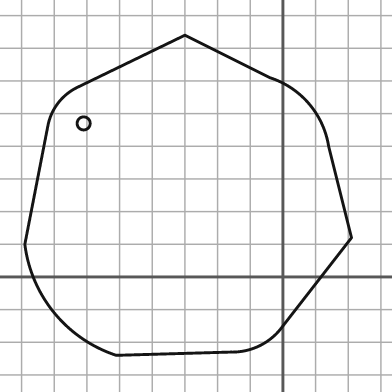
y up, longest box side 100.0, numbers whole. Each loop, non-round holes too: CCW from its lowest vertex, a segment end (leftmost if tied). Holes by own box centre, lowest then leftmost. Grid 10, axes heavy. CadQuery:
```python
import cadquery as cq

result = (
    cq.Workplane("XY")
    .moveTo(-51.0, -24.0)
    .lineTo(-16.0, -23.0)
    .threePointArc((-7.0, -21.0), (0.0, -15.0))
    .lineTo(21.0, 12.0)
    .lineTo(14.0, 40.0)
    .threePointArc((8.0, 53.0), (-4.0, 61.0))
    .lineTo(-30.0, 74.0)
    .lineTo(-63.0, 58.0)
    .threePointArc((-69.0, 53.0), (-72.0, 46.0))
    .lineTo(-79.0, 10.0)
    .threePointArc((-70.0, -11.0), (-51.0, -24.0))
    .close()
    .moveTo(-61.0, 47.0)
    .circle(2.0)
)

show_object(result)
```